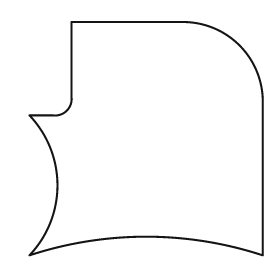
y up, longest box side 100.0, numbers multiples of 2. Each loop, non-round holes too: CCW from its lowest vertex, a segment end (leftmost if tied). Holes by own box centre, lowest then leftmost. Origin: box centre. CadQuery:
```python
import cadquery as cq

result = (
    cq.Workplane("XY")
    .moveTo(-50.0, -50.0)
    .threePointArc((0.0, -42.0), (50.0, -50.0))
    .lineTo(50.0, 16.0)
    .threePointArc((40.0, 40.0), (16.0, 50.0))
    .lineTo(-32.0, 50.0)
    .lineTo(-32.0, 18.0)
    .threePointArc((-34.0, 12.0), (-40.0, 10.0))
    .lineTo(-50.0, 10.0)
    .threePointArc((-38.0, -20.0), (-50.0, -50.0))
    .close()
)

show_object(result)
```